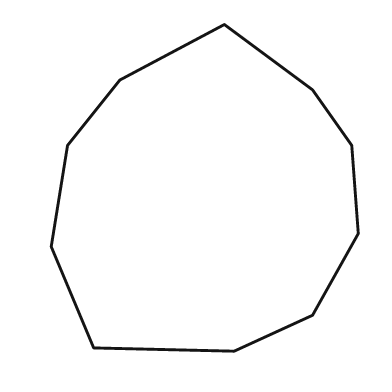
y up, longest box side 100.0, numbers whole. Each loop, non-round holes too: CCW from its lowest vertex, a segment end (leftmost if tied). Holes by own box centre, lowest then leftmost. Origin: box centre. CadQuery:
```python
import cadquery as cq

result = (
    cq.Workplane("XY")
    .moveTo(9.0, -50.0)
    .lineTo(33.0, -39.0)
    .lineTo(47.0, -14.0)
    .lineTo(45.0, 13.0)
    .lineTo(33.0, 30.0)
    .lineTo(6.0, 50.0)
    .lineTo(-26.0, 33.0)
    .lineTo(-42.0, 13.0)
    .lineTo(-47.0, -18.0)
    .lineTo(-34.0, -49.0)
    .close()
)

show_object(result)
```